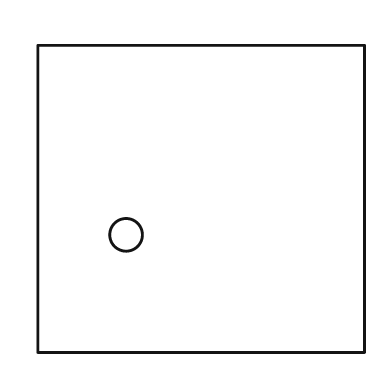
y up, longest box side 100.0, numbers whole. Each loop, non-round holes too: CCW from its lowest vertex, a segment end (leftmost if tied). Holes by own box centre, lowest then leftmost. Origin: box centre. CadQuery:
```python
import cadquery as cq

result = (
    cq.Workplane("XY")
    .moveTo(-50.0, -47.0)
    .lineTo(50.0, -47.0)
    .lineTo(50.0, 47.0)
    .lineTo(-50.0, 47.0)
    .close()
    .moveTo(-23.0, -11.0)
    .circle(5.0)
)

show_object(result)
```